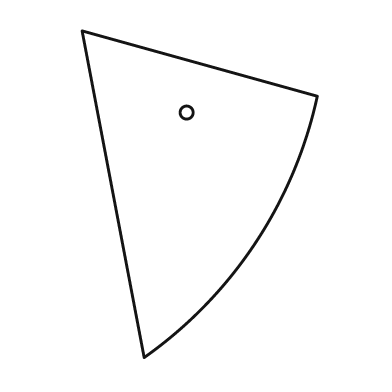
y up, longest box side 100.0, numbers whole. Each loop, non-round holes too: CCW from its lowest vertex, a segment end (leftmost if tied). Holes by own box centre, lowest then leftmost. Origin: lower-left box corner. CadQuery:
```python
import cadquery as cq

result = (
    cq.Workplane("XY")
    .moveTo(19.0, 0.0)
    .threePointArc((53.0, 35.0), (72.0, 80.0))
    .lineTo(0.0, 100.0)
    .close()
    .moveTo(32.0, 75.0)
    .circle(2.0)
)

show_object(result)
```